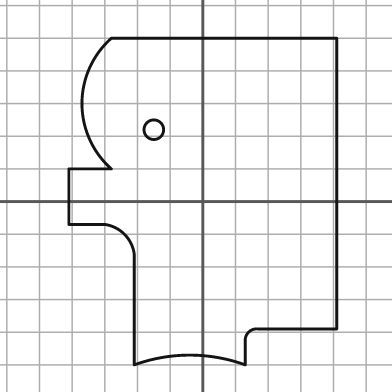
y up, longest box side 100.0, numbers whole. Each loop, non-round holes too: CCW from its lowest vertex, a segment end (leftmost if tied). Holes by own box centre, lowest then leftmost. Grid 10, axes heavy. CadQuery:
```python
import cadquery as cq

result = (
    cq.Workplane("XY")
    .moveTo(-21.0, -50.0)
    .threePointArc((-4.0, -47.0), (13.0, -50.0))
    .lineTo(13.0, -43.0)
    .threePointArc((14.0, -40.0), (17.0, -39.0))
    .lineTo(41.0, -39.0)
    .lineTo(41.0, 50.0)
    .lineTo(-28.0, 50.0)
    .threePointArc((-37.0, 30.0), (-28.0, 10.0))
    .lineTo(-41.0, 10.0)
    .lineTo(-41.0, -7.0)
    .lineTo(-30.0, -7.0)
    .threePointArc((-24.0, -10.0), (-21.0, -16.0))
    .close()
    .moveTo(-15.0, 22.0)
    .circle(3.0)
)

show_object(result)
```